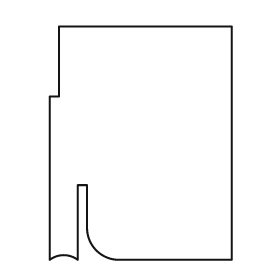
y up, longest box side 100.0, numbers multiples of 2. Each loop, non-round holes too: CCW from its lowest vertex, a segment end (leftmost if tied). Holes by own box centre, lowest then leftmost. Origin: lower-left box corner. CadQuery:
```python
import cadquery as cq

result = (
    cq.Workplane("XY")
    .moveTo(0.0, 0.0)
    .threePointArc((6.0, 2.0), (12.0, 0.0))
    .lineTo(12.0, 32.0)
    .lineTo(16.0, 32.0)
    .lineTo(16.0, 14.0)
    .threePointArc((20.0, 4.0), (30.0, 0.0))
    .lineTo(78.0, 0.0)
    .lineTo(78.0, 100.0)
    .lineTo(4.0, 100.0)
    .lineTo(4.0, 70.0)
    .lineTo(0.0, 70.0)
    .close()
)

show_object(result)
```